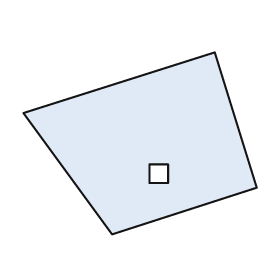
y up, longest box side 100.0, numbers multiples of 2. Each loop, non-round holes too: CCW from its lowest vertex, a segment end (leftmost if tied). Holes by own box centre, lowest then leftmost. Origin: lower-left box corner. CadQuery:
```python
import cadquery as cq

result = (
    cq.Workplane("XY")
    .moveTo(38.0, 0.0)
    .lineTo(100.0, 20.0)
    .lineTo(82.0, 78.0)
    .lineTo(0.0, 52.0)
    .close()
    .moveTo(54.0, 22.0)
    .lineTo(62.0, 22.0)
    .lineTo(62.0, 30.0)
    .lineTo(54.0, 30.0)
    .close()
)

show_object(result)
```